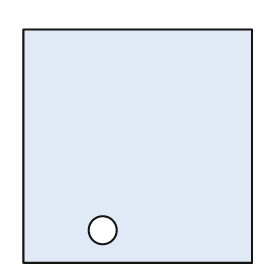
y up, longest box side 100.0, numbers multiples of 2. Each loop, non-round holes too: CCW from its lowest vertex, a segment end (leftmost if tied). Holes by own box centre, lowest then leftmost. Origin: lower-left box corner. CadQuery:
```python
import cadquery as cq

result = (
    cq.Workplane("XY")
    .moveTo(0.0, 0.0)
    .lineTo(98.0, 0.0)
    .lineTo(98.0, 100.0)
    .lineTo(0.0, 100.0)
    .close()
    .moveTo(34.0, 14.0)
    .circle(6.0)
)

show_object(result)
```